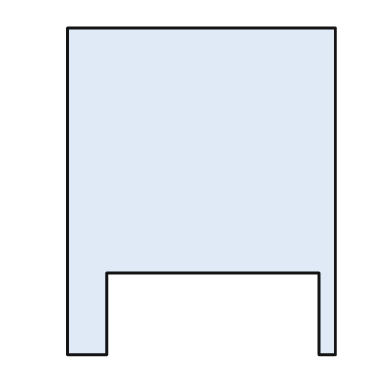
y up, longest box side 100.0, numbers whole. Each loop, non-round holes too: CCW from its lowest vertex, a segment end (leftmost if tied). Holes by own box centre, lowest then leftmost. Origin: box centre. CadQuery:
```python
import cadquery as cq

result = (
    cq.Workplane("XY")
    .moveTo(-41.0, -50.0)
    .lineTo(-29.0, -50.0)
    .lineTo(-29.0, -25.0)
    .lineTo(36.0, -25.0)
    .lineTo(36.0, -50.0)
    .lineTo(41.0, -50.0)
    .lineTo(41.0, 50.0)
    .lineTo(-41.0, 50.0)
    .close()
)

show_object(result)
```